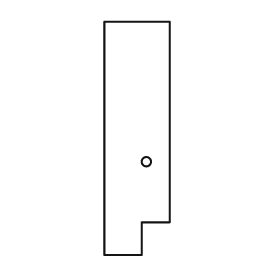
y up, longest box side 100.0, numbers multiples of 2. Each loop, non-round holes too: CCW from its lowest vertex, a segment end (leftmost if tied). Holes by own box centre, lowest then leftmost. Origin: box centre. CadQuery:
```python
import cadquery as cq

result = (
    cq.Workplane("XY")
    .moveTo(-14.0, -50.0)
    .lineTo(2.0, -50.0)
    .lineTo(2.0, -36.0)
    .lineTo(14.0, -36.0)
    .lineTo(14.0, 50.0)
    .lineTo(-14.0, 50.0)
    .close()
    .moveTo(4.0, -10.0)
    .circle(2.0)
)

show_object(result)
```